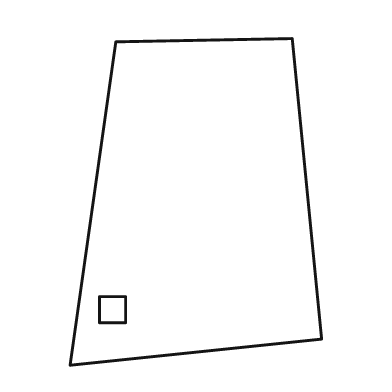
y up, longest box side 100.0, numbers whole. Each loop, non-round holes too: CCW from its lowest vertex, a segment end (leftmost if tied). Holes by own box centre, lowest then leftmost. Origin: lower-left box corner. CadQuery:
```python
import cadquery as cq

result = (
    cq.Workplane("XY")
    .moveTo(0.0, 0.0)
    .lineTo(77.0, 8.0)
    .lineTo(68.0, 100.0)
    .lineTo(14.0, 99.0)
    .close()
    .moveTo(9.0, 13.0)
    .lineTo(17.0, 13.0)
    .lineTo(17.0, 21.0)
    .lineTo(9.0, 21.0)
    .close()
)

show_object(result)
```